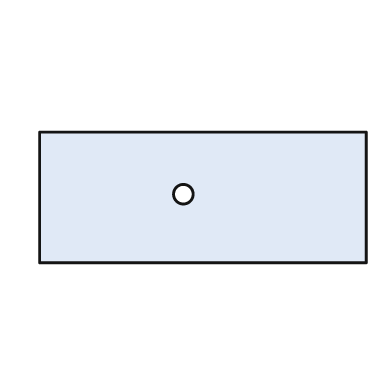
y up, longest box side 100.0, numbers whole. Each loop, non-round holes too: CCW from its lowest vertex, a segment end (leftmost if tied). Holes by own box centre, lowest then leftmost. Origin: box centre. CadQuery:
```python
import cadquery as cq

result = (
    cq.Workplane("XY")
    .moveTo(-50.0, -20.0)
    .lineTo(50.0, -20.0)
    .lineTo(50.0, 20.0)
    .lineTo(-50.0, 20.0)
    .close()
    .moveTo(-6.0, 1.0)
    .circle(3.0)
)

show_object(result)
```